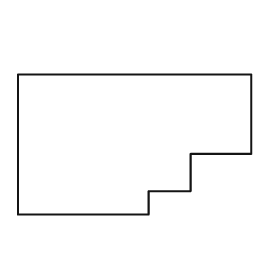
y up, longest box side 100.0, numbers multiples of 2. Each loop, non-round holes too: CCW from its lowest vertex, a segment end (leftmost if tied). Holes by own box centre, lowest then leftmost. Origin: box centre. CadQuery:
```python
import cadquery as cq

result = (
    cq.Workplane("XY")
    .moveTo(-50.0, -30.0)
    .lineTo(6.0, -30.0)
    .lineTo(6.0, -20.0)
    .lineTo(24.0, -20.0)
    .lineTo(24.0, -4.0)
    .lineTo(50.0, -4.0)
    .lineTo(50.0, 30.0)
    .lineTo(-50.0, 30.0)
    .close()
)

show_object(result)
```